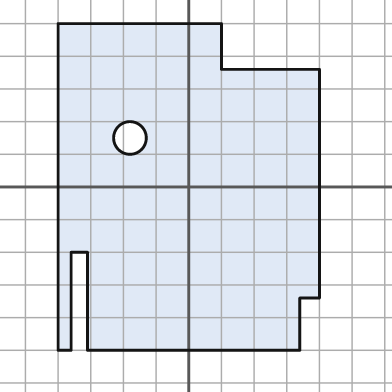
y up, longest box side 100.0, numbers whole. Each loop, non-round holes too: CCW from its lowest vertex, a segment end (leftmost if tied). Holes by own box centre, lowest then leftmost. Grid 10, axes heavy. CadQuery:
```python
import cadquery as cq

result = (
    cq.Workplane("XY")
    .moveTo(-40.0, -50.0)
    .lineTo(-36.0, -50.0)
    .lineTo(-36.0, -20.0)
    .lineTo(-31.0, -20.0)
    .lineTo(-31.0, -50.0)
    .lineTo(34.0, -50.0)
    .lineTo(34.0, -34.0)
    .lineTo(40.0, -34.0)
    .lineTo(40.0, 36.0)
    .lineTo(10.0, 36.0)
    .lineTo(10.0, 50.0)
    .lineTo(-40.0, 50.0)
    .close()
    .moveTo(-18.0, 15.0)
    .circle(5.0)
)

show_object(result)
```